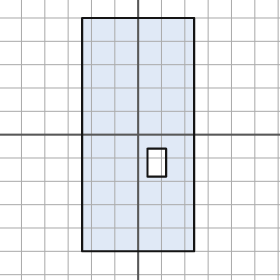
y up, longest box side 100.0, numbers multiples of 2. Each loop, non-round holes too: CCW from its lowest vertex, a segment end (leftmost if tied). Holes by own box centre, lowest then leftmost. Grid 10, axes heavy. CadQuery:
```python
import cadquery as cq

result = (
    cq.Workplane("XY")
    .moveTo(-24.0, -50.0)
    .lineTo(24.0, -50.0)
    .lineTo(24.0, 50.0)
    .lineTo(-24.0, 50.0)
    .close()
    .moveTo(4.0, -18.0)
    .lineTo(12.0, -18.0)
    .lineTo(12.0, -6.0)
    .lineTo(4.0, -6.0)
    .close()
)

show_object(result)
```